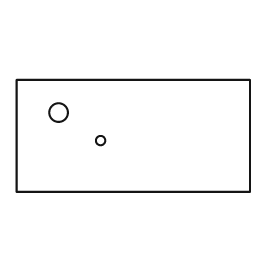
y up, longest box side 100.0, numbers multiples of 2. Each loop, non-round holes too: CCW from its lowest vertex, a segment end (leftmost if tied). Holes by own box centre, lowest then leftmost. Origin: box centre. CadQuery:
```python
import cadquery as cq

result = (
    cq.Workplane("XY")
    .moveTo(-50.0, -24.0)
    .lineTo(50.0, -24.0)
    .lineTo(50.0, 24.0)
    .lineTo(-50.0, 24.0)
    .close()
    .moveTo(-14.0, -2.0)
    .circle(2.0)
    .moveTo(-32.0, 10.0)
    .circle(4.0)
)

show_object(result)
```